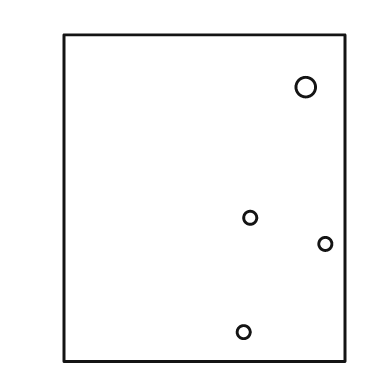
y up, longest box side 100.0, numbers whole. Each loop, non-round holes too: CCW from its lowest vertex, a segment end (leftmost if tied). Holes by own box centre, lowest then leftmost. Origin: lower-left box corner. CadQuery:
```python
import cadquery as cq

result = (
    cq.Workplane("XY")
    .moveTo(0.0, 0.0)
    .lineTo(86.0, 0.0)
    .lineTo(86.0, 100.0)
    .lineTo(0.0, 100.0)
    .close()
    .moveTo(55.0, 9.0)
    .circle(2.0)
    .moveTo(80.0, 36.0)
    .circle(2.0)
    .moveTo(57.0, 44.0)
    .circle(2.0)
    .moveTo(74.0, 84.0)
    .circle(3.0)
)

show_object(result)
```